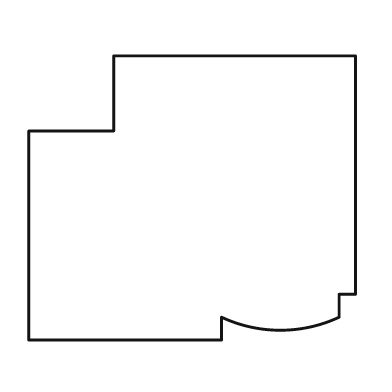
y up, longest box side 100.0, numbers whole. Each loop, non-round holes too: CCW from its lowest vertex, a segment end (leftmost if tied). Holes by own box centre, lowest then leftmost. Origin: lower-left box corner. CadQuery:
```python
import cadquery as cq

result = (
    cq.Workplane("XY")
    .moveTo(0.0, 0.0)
    .lineTo(59.0, 0.0)
    .lineTo(59.0, 7.0)
    .threePointArc((77.0, 3.0), (95.0, 7.0))
    .lineTo(95.0, 14.0)
    .lineTo(100.0, 14.0)
    .lineTo(100.0, 87.0)
    .lineTo(26.0, 87.0)
    .lineTo(26.0, 64.0)
    .lineTo(0.0, 64.0)
    .close()
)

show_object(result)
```